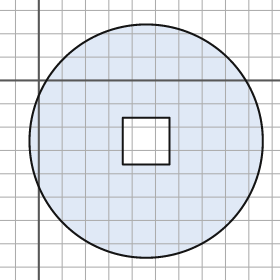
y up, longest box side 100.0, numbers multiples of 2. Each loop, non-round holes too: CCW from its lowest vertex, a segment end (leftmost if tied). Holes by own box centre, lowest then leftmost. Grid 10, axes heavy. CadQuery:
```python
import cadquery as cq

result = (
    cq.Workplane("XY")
    .moveTo(46.0, -26.0)
    .circle(50.0)
    .moveTo(36.0, -36.0)
    .lineTo(56.0, -36.0)
    .lineTo(56.0, -16.0)
    .lineTo(36.0, -16.0)
    .close()
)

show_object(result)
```